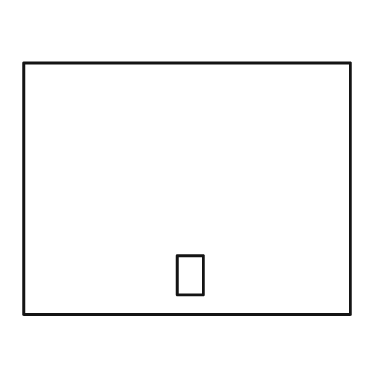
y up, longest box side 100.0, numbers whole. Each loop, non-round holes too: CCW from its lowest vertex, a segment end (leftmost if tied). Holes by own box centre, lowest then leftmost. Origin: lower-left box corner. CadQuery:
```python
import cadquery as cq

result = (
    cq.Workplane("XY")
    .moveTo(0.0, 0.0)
    .lineTo(100.0, 0.0)
    .lineTo(100.0, 77.0)
    .lineTo(0.0, 77.0)
    .close()
    .moveTo(47.0, 6.0)
    .lineTo(55.0, 6.0)
    .lineTo(55.0, 18.0)
    .lineTo(47.0, 18.0)
    .close()
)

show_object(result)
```